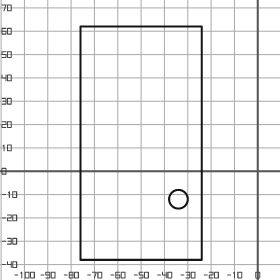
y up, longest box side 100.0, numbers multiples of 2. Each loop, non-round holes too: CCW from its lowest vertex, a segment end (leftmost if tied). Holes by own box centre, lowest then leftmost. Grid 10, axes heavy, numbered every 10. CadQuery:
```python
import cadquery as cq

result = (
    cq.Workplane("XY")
    .moveTo(-76.0, -38.0)
    .lineTo(-24.0, -38.0)
    .lineTo(-24.0, 62.0)
    .lineTo(-76.0, 62.0)
    .close()
    .moveTo(-34.0, -12.0)
    .circle(4.0)
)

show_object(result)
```